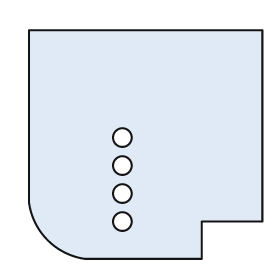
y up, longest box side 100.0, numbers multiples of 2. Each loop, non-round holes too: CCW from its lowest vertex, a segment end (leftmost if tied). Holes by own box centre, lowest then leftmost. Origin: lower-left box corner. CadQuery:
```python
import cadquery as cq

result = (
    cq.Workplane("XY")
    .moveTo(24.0, 0.0)
    .lineTo(74.0, 0.0)
    .lineTo(74.0, 16.0)
    .lineTo(100.0, 16.0)
    .lineTo(100.0, 98.0)
    .lineTo(0.0, 98.0)
    .lineTo(0.0, 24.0)
    .threePointArc((8.0, 8.0), (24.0, 0.0))
    .close()
    .moveTo(40.0, 16.0)
    .circle(4.0)
    .moveTo(40.0, 28.0)
    .circle(4.0)
    .moveTo(40.0, 40.0)
    .circle(4.0)
    .moveTo(40.0, 52.0)
    .circle(4.0)
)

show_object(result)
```